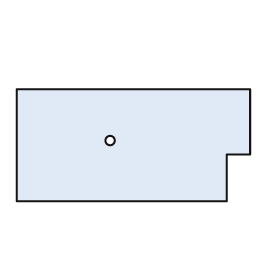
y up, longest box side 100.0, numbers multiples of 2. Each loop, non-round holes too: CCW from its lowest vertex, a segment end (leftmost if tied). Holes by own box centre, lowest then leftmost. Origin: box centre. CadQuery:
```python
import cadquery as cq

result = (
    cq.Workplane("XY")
    .moveTo(-50.0, -24.0)
    .lineTo(40.0, -24.0)
    .lineTo(40.0, -4.0)
    .lineTo(50.0, -4.0)
    .lineTo(50.0, 24.0)
    .lineTo(-50.0, 24.0)
    .close()
    .moveTo(-10.0, 2.0)
    .circle(2.0)
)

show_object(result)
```